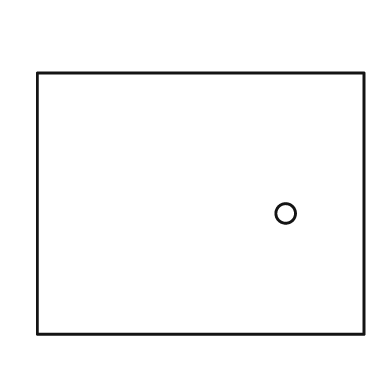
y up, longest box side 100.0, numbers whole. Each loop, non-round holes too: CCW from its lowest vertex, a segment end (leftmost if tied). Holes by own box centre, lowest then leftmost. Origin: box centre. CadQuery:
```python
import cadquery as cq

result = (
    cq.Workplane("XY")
    .moveTo(-50.0, -40.0)
    .lineTo(50.0, -40.0)
    .lineTo(50.0, 40.0)
    .lineTo(-50.0, 40.0)
    .close()
    .moveTo(26.0, -3.0)
    .circle(3.0)
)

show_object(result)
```